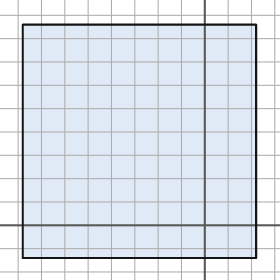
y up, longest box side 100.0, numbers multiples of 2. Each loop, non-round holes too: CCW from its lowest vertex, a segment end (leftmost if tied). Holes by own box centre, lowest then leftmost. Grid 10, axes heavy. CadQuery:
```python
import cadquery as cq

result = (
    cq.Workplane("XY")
    .moveTo(-78.0, -14.0)
    .lineTo(22.0, -14.0)
    .lineTo(22.0, 86.0)
    .lineTo(-78.0, 86.0)
    .close()
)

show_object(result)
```